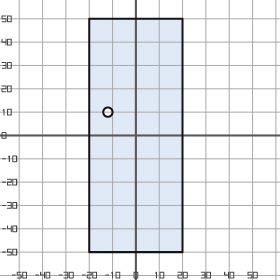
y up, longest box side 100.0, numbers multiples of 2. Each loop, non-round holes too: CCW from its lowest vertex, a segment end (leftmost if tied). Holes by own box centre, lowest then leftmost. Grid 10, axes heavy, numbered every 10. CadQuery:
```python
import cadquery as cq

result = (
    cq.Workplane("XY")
    .moveTo(-20.0, -50.0)
    .lineTo(20.0, -50.0)
    .lineTo(20.0, 50.0)
    .lineTo(-20.0, 50.0)
    .close()
    .moveTo(-12.0, 10.0)
    .circle(2.0)
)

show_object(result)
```